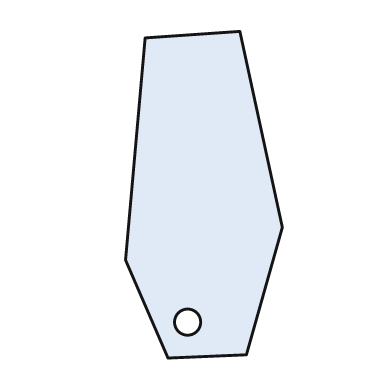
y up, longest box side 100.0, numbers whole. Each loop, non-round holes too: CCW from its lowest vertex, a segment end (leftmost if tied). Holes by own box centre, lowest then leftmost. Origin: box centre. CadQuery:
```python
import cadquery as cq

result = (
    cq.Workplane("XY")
    .moveTo(-11.0, -50.0)
    .lineTo(13.0, -49.0)
    .lineTo(24.0, -10.0)
    .lineTo(11.0, 50.0)
    .lineTo(-18.0, 48.0)
    .lineTo(-24.0, -20.0)
    .close()
    .moveTo(-5.0, -39.0)
    .circle(4.0)
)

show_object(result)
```